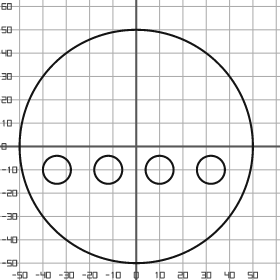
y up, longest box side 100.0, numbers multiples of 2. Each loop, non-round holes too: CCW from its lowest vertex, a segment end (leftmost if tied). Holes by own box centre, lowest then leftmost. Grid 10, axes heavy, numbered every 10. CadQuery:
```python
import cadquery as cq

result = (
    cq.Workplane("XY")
    .moveTo(0.0, 0.0)
    .circle(50.0)
    .moveTo(-34.0, -10.0)
    .circle(6.0)
    .moveTo(-12.0, -10.0)
    .circle(6.0)
    .moveTo(10.0, -10.0)
    .circle(6.0)
    .moveTo(32.0, -10.0)
    .circle(6.0)
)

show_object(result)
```